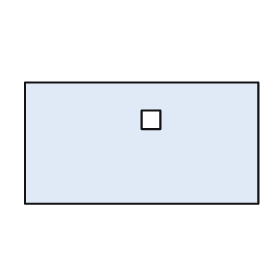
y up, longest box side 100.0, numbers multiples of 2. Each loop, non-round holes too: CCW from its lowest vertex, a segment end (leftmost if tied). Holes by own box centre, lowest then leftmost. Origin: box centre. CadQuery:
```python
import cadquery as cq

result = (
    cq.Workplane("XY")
    .moveTo(-50.0, -26.0)
    .lineTo(50.0, -26.0)
    .lineTo(50.0, 26.0)
    .lineTo(-50.0, 26.0)
    .close()
    .moveTo(0.0, 6.0)
    .lineTo(8.0, 6.0)
    .lineTo(8.0, 14.0)
    .lineTo(0.0, 14.0)
    .close()
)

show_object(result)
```